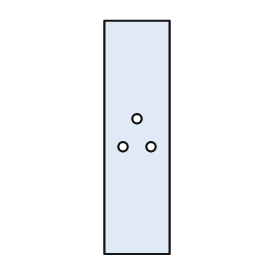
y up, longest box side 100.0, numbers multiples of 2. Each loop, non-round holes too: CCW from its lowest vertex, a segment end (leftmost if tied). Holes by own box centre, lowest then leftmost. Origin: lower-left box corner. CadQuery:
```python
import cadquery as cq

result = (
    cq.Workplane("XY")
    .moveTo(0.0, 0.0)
    .lineTo(28.0, 0.0)
    .lineTo(28.0, 100.0)
    .lineTo(0.0, 100.0)
    .close()
    .moveTo(8.0, 46.0)
    .circle(2.0)
    .moveTo(20.0, 46.0)
    .circle(2.0)
    .moveTo(14.0, 58.0)
    .circle(2.0)
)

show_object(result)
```